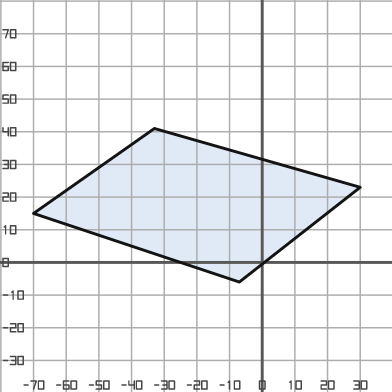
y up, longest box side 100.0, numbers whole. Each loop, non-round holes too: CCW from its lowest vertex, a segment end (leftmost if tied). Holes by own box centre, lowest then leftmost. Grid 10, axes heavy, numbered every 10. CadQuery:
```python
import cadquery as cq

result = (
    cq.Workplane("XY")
    .moveTo(-7.0, -6.0)
    .lineTo(30.0, 23.0)
    .lineTo(-33.0, 41.0)
    .lineTo(-70.0, 15.0)
    .close()
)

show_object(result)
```